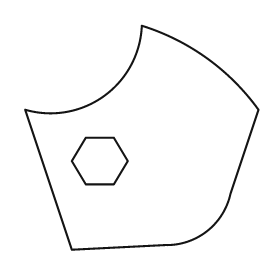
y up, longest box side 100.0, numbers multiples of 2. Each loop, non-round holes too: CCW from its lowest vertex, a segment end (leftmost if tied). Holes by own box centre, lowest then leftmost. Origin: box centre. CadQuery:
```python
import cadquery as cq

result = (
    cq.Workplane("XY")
    .moveTo(-30.0, -48.0)
    .lineTo(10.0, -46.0)
    .threePointArc((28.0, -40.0), (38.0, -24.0))
    .lineTo(50.0, 12.0)
    .threePointArc((28.0, 34.0), (0.0, 48.0))
    .threePointArc((-16.0, 18.0), (-50.0, 12.0))
    .close()
    .moveTo(-24.0, -20.0)
    .lineTo(-12.0, -20.0)
    .lineTo(-6.0, -10.0)
    .lineTo(-12.0, 0.0)
    .lineTo(-24.0, 0.0)
    .lineTo(-30.0, -10.0)
    .close()
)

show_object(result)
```